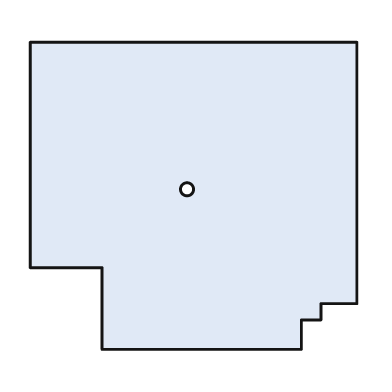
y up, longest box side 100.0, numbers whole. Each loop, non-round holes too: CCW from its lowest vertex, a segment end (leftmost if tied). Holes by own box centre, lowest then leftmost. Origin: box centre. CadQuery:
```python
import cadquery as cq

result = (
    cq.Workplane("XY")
    .moveTo(-28.0, -47.0)
    .lineTo(33.0, -47.0)
    .lineTo(33.0, -38.0)
    .lineTo(39.0, -38.0)
    .lineTo(39.0, -33.0)
    .lineTo(50.0, -33.0)
    .lineTo(50.0, 47.0)
    .lineTo(-50.0, 47.0)
    .lineTo(-50.0, -22.0)
    .lineTo(-28.0, -22.0)
    .close()
    .moveTo(-2.0, 2.0)
    .circle(2.0)
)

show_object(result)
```